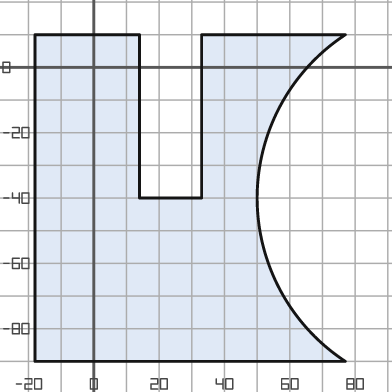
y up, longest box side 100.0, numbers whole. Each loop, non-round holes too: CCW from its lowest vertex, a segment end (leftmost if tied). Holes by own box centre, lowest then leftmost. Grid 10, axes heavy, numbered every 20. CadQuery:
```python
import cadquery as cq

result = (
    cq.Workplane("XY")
    .moveTo(-18.0, -90.0)
    .lineTo(77.0, -90.0)
    .threePointArc((50.0, -40.0), (77.0, 10.0))
    .lineTo(33.0, 10.0)
    .lineTo(33.0, -40.0)
    .lineTo(14.0, -40.0)
    .lineTo(14.0, 10.0)
    .lineTo(-18.0, 10.0)
    .close()
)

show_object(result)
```